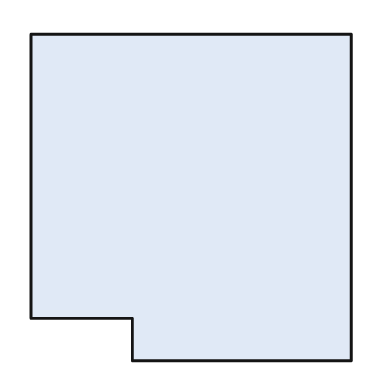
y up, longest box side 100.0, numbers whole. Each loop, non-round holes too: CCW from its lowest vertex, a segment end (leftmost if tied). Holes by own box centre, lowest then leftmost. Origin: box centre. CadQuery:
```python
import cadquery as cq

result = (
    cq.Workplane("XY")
    .moveTo(-18.0, -50.0)
    .lineTo(49.0, -50.0)
    .lineTo(49.0, 50.0)
    .lineTo(-49.0, 50.0)
    .lineTo(-49.0, -37.0)
    .lineTo(-18.0, -37.0)
    .close()
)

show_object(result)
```